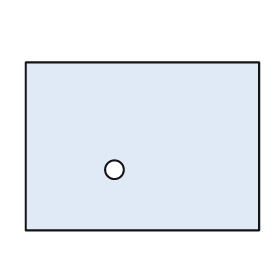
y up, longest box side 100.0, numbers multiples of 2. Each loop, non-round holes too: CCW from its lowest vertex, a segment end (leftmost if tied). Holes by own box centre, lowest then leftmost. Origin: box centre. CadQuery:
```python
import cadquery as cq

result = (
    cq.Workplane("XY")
    .moveTo(-50.0, -36.0)
    .lineTo(50.0, -36.0)
    .lineTo(50.0, 36.0)
    .lineTo(-50.0, 36.0)
    .close()
    .moveTo(-12.0, -10.0)
    .circle(4.0)
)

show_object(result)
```